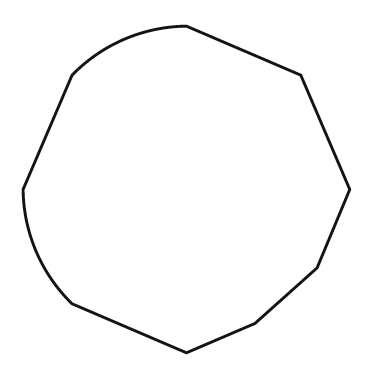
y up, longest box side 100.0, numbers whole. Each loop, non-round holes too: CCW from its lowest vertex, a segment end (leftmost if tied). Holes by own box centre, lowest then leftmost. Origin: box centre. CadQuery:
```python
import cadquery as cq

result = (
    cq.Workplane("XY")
    .moveTo(0.0, -50.0)
    .lineTo(21.0, -41.0)
    .lineTo(40.0, -24.0)
    .lineTo(50.0, 0.0)
    .lineTo(35.0, 35.0)
    .lineTo(0.0, 50.0)
    .threePointArc((-19.0, 46.0), (-35.0, 35.0))
    .lineTo(-50.0, 0.0)
    .threePointArc((-46.0, -19.0), (-35.0, -35.0))
    .close()
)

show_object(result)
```